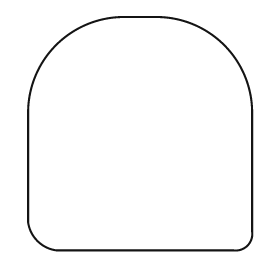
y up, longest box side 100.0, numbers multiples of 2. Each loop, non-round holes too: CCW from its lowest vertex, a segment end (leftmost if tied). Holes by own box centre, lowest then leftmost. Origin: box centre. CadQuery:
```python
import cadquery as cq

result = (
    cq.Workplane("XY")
    .moveTo(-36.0, -50.0)
    .lineTo(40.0, -50.0)
    .threePointArc((46.0, -48.0), (48.0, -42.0))
    .lineTo(48.0, 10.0)
    .threePointArc((36.0, 38.0), (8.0, 50.0))
    .lineTo(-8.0, 50.0)
    .threePointArc((-36.0, 38.0), (-48.0, 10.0))
    .lineTo(-48.0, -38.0)
    .threePointArc((-44.0, -46.0), (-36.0, -50.0))
    .close()
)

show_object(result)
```